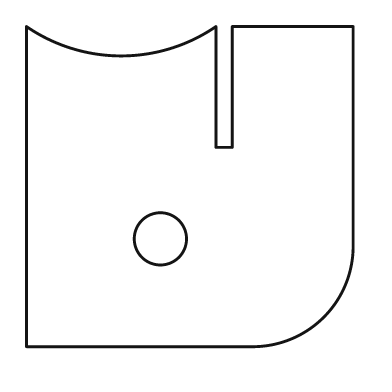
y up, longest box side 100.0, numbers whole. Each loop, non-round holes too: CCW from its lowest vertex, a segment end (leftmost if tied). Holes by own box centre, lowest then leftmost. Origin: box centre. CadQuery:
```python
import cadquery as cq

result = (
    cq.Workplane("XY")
    .moveTo(-50.0, -49.0)
    .lineTo(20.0, -49.0)
    .threePointArc((41.0, -40.0), (50.0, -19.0))
    .lineTo(50.0, 49.0)
    .lineTo(13.0, 49.0)
    .lineTo(13.0, 12.0)
    .lineTo(8.0, 12.0)
    .lineTo(8.0, 49.0)
    .threePointArc((-21.0, 40.0), (-50.0, 49.0))
    .close()
    .moveTo(-9.0, -16.0)
    .circle(8.0)
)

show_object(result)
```